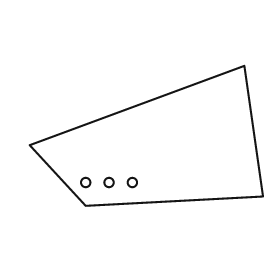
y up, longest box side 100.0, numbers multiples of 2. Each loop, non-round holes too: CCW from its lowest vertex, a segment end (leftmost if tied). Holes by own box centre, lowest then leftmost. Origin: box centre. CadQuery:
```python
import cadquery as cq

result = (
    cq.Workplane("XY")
    .moveTo(-26.0, -30.0)
    .lineTo(50.0, -26.0)
    .lineTo(42.0, 30.0)
    .lineTo(-50.0, -4.0)
    .close()
    .moveTo(-26.0, -20.0)
    .circle(2.0)
    .moveTo(-16.0, -20.0)
    .circle(2.0)
    .moveTo(-6.0, -20.0)
    .circle(2.0)
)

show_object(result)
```